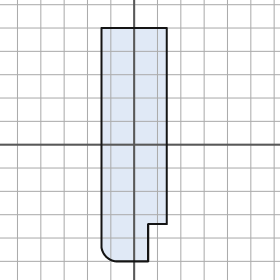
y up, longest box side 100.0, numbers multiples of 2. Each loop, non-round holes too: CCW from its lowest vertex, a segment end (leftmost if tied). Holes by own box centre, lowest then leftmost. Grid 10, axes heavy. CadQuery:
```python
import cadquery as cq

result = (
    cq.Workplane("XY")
    .moveTo(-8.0, -50.0)
    .lineTo(6.0, -50.0)
    .lineTo(6.0, -34.0)
    .lineTo(14.0, -34.0)
    .lineTo(14.0, 50.0)
    .lineTo(-14.0, 50.0)
    .lineTo(-14.0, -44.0)
    .threePointArc((-12.0, -48.0), (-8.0, -50.0))
    .close()
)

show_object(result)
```